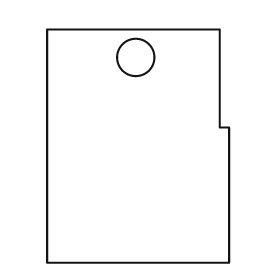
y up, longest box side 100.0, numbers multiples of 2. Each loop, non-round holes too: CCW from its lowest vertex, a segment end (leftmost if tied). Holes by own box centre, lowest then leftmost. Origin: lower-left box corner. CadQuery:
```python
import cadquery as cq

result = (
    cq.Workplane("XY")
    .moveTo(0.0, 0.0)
    .lineTo(78.0, 0.0)
    .lineTo(78.0, 58.0)
    .lineTo(74.0, 58.0)
    .lineTo(74.0, 100.0)
    .lineTo(0.0, 100.0)
    .close()
    .moveTo(38.0, 88.0)
    .circle(8.0)
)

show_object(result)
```